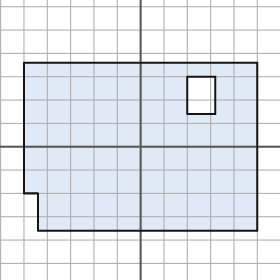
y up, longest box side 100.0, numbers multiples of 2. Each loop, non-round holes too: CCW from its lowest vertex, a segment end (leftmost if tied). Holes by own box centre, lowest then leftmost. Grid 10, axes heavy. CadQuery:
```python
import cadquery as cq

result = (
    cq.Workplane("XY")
    .moveTo(-44.0, -36.0)
    .lineTo(50.0, -36.0)
    .lineTo(50.0, 36.0)
    .lineTo(-50.0, 36.0)
    .lineTo(-50.0, -20.0)
    .lineTo(-44.0, -20.0)
    .close()
    .moveTo(20.0, 14.0)
    .lineTo(32.0, 14.0)
    .lineTo(32.0, 30.0)
    .lineTo(20.0, 30.0)
    .close()
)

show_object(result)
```